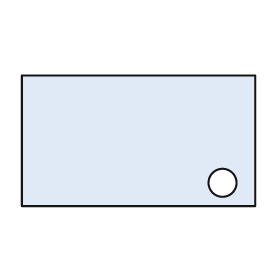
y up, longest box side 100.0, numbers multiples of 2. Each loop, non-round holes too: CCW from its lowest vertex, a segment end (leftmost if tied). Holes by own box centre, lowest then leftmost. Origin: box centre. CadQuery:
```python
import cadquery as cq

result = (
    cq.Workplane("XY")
    .moveTo(-50.0, -28.0)
    .lineTo(50.0, -28.0)
    .lineTo(50.0, 28.0)
    .lineTo(-50.0, 28.0)
    .close()
    .moveTo(36.0, -18.0)
    .circle(6.0)
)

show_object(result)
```